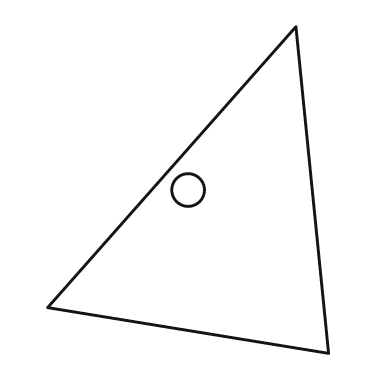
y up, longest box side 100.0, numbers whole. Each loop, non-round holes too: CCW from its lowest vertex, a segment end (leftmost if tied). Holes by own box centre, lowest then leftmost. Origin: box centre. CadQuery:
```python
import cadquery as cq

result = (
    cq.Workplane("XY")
    .moveTo(43.0, -50.0)
    .lineTo(33.0, 50.0)
    .lineTo(-43.0, -36.0)
    .close()
    .moveTo(0.0, 0.0)
    .circle(5.0)
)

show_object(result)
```